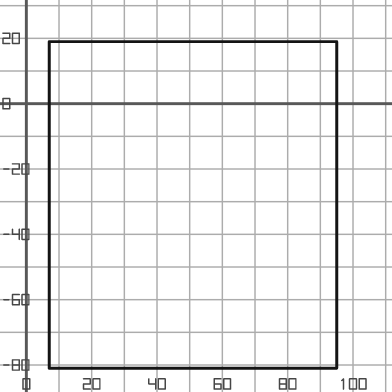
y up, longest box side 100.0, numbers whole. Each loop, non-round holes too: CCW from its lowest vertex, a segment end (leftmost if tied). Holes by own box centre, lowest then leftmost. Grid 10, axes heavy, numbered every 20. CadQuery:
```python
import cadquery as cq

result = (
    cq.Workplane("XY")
    .moveTo(7.0, -81.0)
    .lineTo(95.0, -81.0)
    .lineTo(95.0, 19.0)
    .lineTo(7.0, 19.0)
    .close()
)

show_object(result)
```